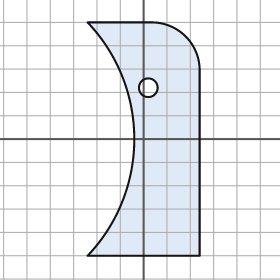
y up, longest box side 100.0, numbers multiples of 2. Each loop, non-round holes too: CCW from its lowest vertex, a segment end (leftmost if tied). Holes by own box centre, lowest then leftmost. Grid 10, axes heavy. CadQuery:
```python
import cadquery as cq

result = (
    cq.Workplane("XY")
    .moveTo(-24.0, -50.0)
    .lineTo(24.0, -50.0)
    .lineTo(24.0, 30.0)
    .threePointArc((18.0, 44.0), (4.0, 50.0))
    .lineTo(-24.0, 50.0)
    .threePointArc((-4.0, 0.0), (-24.0, -50.0))
    .close()
    .moveTo(2.0, 22.0)
    .circle(4.0)
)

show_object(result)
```